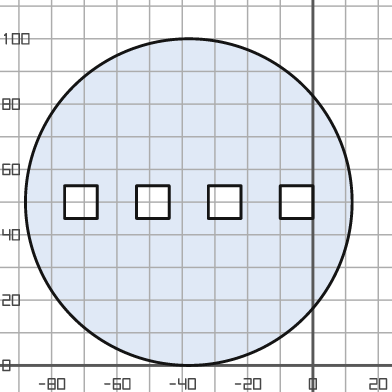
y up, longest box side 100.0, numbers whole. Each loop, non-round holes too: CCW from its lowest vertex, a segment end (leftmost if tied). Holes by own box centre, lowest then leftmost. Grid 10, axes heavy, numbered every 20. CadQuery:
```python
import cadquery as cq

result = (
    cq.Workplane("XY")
    .moveTo(-38.0, 50.0)
    .circle(50.0)
    .moveTo(-76.0, 45.0)
    .lineTo(-66.0, 45.0)
    .lineTo(-66.0, 55.0)
    .lineTo(-76.0, 55.0)
    .close()
    .moveTo(-54.0, 45.0)
    .lineTo(-44.0, 45.0)
    .lineTo(-44.0, 55.0)
    .lineTo(-54.0, 55.0)
    .close()
    .moveTo(-32.0, 45.0)
    .lineTo(-22.0, 45.0)
    .lineTo(-22.0, 55.0)
    .lineTo(-32.0, 55.0)
    .close()
    .moveTo(-10.0, 45.0)
    .lineTo(0.0, 45.0)
    .lineTo(0.0, 55.0)
    .lineTo(-10.0, 55.0)
    .close()
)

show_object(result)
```